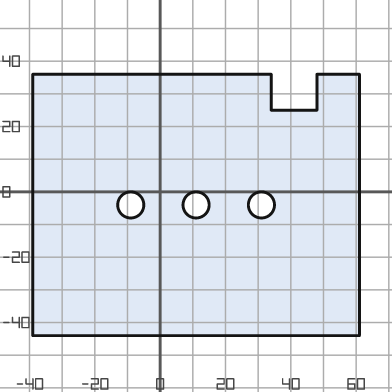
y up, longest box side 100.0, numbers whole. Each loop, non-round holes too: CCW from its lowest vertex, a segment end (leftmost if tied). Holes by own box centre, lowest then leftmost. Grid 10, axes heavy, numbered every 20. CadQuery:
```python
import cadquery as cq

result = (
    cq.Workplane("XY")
    .moveTo(-39.0, -44.0)
    .lineTo(61.0, -44.0)
    .lineTo(61.0, 36.0)
    .lineTo(48.0, 36.0)
    .lineTo(48.0, 25.0)
    .lineTo(34.0, 25.0)
    .lineTo(34.0, 36.0)
    .lineTo(-39.0, 36.0)
    .close()
    .moveTo(-9.0, -4.0)
    .circle(4.0)
    .moveTo(11.0, -4.0)
    .circle(4.0)
    .moveTo(31.0, -4.0)
    .circle(4.0)
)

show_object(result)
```